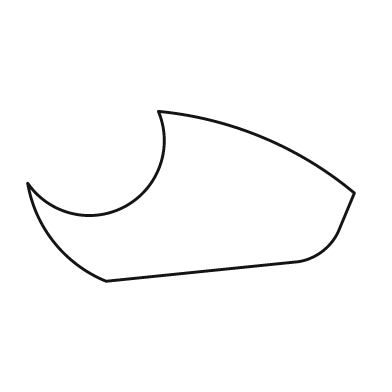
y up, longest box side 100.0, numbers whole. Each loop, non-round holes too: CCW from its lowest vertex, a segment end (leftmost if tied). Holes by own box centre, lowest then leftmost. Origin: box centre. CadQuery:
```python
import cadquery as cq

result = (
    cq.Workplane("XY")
    .moveTo(-26.0, -26.0)
    .lineTo(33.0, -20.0)
    .threePointArc((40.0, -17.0), (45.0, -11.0))
    .lineTo(50.0, 1.0)
    .threePointArc((22.0, 18.0), (-10.0, 26.0))
    .threePointArc((-20.0, -3.0), (-50.0, 4.0))
    .threePointArc((-42.0, -14.0), (-26.0, -26.0))
    .close()
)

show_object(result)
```